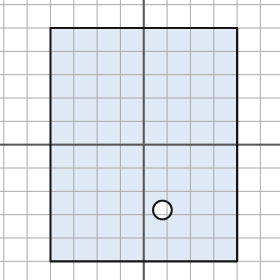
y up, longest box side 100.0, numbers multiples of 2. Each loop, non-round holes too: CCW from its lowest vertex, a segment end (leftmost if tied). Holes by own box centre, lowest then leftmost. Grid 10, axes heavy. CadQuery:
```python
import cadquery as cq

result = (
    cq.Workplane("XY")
    .moveTo(-40.0, -50.0)
    .lineTo(40.0, -50.0)
    .lineTo(40.0, 50.0)
    .lineTo(-40.0, 50.0)
    .close()
    .moveTo(8.0, -28.0)
    .circle(4.0)
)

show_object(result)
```